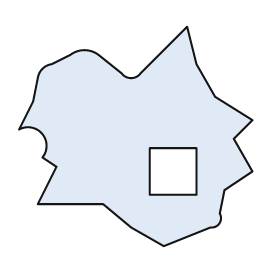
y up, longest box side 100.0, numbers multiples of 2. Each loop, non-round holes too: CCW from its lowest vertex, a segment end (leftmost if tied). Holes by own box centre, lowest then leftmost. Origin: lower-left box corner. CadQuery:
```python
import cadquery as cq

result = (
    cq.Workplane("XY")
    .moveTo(62.0, 0.0)
    .lineTo(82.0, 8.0)
    .threePointArc((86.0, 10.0), (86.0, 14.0))
    .lineTo(88.0, 24.0)
    .lineTo(100.0, 32.0)
    .lineTo(92.0, 46.0)
    .lineTo(100.0, 54.0)
    .lineTo(84.0, 64.0)
    .lineTo(76.0, 78.0)
    .lineTo(72.0, 94.0)
    .lineTo(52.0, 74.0)
    .threePointArc((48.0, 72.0), (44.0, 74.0))
    .lineTo(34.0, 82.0)
    .threePointArc((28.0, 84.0), (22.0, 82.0))
    .lineTo(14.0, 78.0)
    .threePointArc((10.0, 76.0), (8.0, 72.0))
    .lineTo(6.0, 62.0)
    .lineTo(0.0, 50.0)
    .threePointArc((10.0, 48.0), (10.0, 38.0))
    .lineTo(16.0, 34.0)
    .lineTo(8.0, 18.0)
    .lineTo(36.0, 18.0)
    .lineTo(48.0, 8.0)
    .close()
    .moveTo(56.0, 22.0)
    .lineTo(76.0, 22.0)
    .lineTo(76.0, 42.0)
    .lineTo(56.0, 42.0)
    .close()
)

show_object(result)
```